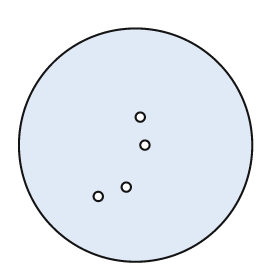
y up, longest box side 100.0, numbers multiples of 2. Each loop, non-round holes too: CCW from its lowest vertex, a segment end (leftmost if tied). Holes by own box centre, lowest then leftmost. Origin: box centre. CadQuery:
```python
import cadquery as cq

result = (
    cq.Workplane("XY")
    .moveTo(0.0, 0.0)
    .circle(50.0)
    .moveTo(-16.0, -22.0)
    .circle(2.0)
    .moveTo(-4.0, -18.0)
    .circle(2.0)
    .moveTo(4.0, 0.0)
    .circle(2.0)
    .moveTo(2.0, 12.0)
    .circle(2.0)
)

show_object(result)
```